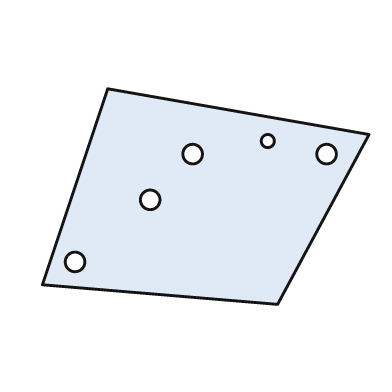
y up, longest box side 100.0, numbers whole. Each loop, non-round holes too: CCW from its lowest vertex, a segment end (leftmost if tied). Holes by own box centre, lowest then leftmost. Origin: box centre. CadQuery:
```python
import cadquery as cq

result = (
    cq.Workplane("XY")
    .moveTo(22.0, -33.0)
    .lineTo(50.0, 19.0)
    .lineTo(-30.0, 33.0)
    .lineTo(-50.0, -27.0)
    .close()
    .moveTo(-40.0, -20.0)
    .circle(3.0)
    .moveTo(-17.0, -1.0)
    .circle(3.0)
    .moveTo(-4.0, 13.0)
    .circle(3.0)
    .moveTo(37.0, 13.0)
    .circle(3.0)
    .moveTo(19.0, 17.0)
    .circle(2.0)
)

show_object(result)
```